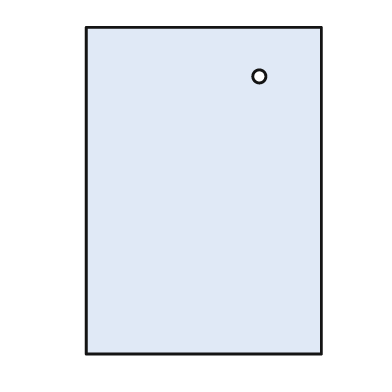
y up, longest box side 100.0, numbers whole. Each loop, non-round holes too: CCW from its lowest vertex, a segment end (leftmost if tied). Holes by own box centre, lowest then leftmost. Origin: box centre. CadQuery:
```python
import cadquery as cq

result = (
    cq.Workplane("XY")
    .moveTo(-36.0, -50.0)
    .lineTo(36.0, -50.0)
    .lineTo(36.0, 50.0)
    .lineTo(-36.0, 50.0)
    .close()
    .moveTo(17.0, 35.0)
    .circle(2.0)
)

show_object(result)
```